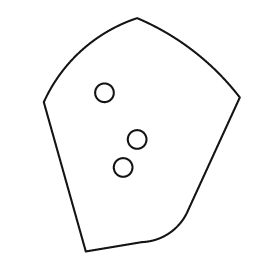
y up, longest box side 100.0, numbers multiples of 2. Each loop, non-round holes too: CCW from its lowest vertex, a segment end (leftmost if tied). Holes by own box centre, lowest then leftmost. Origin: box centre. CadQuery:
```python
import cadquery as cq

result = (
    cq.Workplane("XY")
    .moveTo(-24.0, -50.0)
    .lineTo(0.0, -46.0)
    .threePointArc((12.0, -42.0), (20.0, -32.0))
    .lineTo(42.0, 16.0)
    .threePointArc((22.0, 36.0), (-2.0, 50.0))
    .threePointArc((-26.0, 36.0), (-42.0, 14.0))
    .close()
    .moveTo(-8.0, -14.0)
    .circle(4.0)
    .moveTo(-2.0, -2.0)
    .circle(4.0)
    .moveTo(-16.0, 18.0)
    .circle(4.0)
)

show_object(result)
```